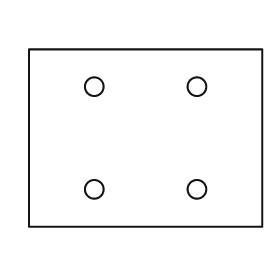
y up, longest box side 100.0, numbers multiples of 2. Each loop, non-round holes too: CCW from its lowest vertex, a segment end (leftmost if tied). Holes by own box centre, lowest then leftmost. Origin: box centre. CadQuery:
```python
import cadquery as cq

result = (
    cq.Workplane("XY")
    .moveTo(-50.0, -38.0)
    .lineTo(50.0, -38.0)
    .lineTo(50.0, 38.0)
    .lineTo(-50.0, 38.0)
    .close()
    .moveTo(-22.0, -22.0)
    .circle(4.0)
    .moveTo(22.0, -22.0)
    .circle(4.0)
    .moveTo(-22.0, 22.0)
    .circle(4.0)
    .moveTo(22.0, 22.0)
    .circle(4.0)
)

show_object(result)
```